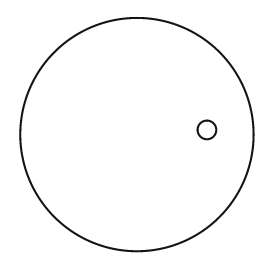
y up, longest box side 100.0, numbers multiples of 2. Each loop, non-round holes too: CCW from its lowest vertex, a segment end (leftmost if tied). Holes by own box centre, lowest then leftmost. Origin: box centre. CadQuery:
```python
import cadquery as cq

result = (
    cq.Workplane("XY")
    .moveTo(0.0, 0.0)
    .circle(50.0)
    .moveTo(30.0, 2.0)
    .circle(4.0)
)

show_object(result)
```